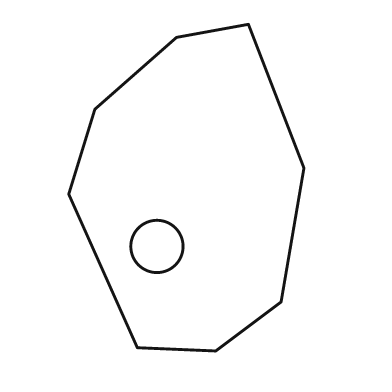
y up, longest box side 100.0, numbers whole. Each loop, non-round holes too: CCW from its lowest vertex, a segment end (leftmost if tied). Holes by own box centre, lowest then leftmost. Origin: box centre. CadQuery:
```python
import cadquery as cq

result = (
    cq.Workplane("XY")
    .moveTo(9.0, -50.0)
    .lineTo(29.0, -35.0)
    .lineTo(36.0, 6.0)
    .lineTo(19.0, 50.0)
    .lineTo(-3.0, 46.0)
    .lineTo(-28.0, 24.0)
    .lineTo(-36.0, -2.0)
    .lineTo(-15.0, -49.0)
    .close()
    .moveTo(-9.0, -18.0)
    .circle(8.0)
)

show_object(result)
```